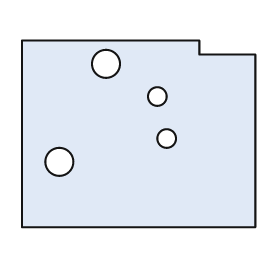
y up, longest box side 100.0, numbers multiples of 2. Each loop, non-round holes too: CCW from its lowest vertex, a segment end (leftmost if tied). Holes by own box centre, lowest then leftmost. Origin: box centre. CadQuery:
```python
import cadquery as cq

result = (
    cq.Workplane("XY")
    .moveTo(-50.0, -40.0)
    .lineTo(50.0, -40.0)
    .lineTo(50.0, 34.0)
    .lineTo(26.0, 34.0)
    .lineTo(26.0, 40.0)
    .lineTo(-50.0, 40.0)
    .close()
    .moveTo(-34.0, -12.0)
    .circle(6.0)
    .moveTo(12.0, -2.0)
    .circle(4.0)
    .moveTo(8.0, 16.0)
    .circle(4.0)
    .moveTo(-14.0, 30.0)
    .circle(6.0)
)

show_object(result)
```